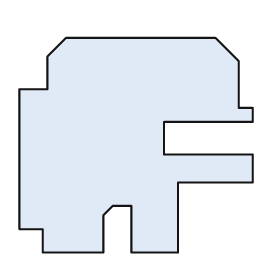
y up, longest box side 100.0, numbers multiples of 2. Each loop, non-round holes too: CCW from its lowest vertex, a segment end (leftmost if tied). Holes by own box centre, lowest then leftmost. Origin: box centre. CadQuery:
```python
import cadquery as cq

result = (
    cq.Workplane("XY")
    .moveTo(-40.0, -46.0)
    .lineTo(-14.0, -46.0)
    .lineTo(-14.0, -30.0)
    .lineTo(-10.0, -26.0)
    .lineTo(-2.0, -26.0)
    .lineTo(-2.0, -46.0)
    .lineTo(18.0, -46.0)
    .lineTo(18.0, -16.0)
    .lineTo(50.0, -16.0)
    .lineTo(50.0, -4.0)
    .lineTo(12.0, -4.0)
    .lineTo(12.0, 10.0)
    .lineTo(50.0, 10.0)
    .lineTo(50.0, 16.0)
    .lineTo(44.0, 16.0)
    .lineTo(44.0, 36.0)
    .lineTo(34.0, 46.0)
    .lineTo(-30.0, 46.0)
    .lineTo(-38.0, 38.0)
    .lineTo(-38.0, 24.0)
    .lineTo(-50.0, 24.0)
    .lineTo(-50.0, -36.0)
    .lineTo(-40.0, -36.0)
    .close()
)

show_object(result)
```